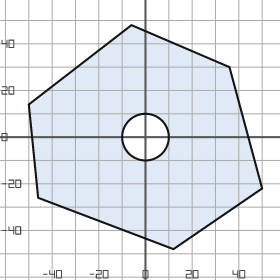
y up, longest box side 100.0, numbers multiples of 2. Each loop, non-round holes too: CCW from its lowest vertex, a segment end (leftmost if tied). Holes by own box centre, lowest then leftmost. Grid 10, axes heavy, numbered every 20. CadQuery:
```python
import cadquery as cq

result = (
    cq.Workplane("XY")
    .moveTo(12.0, -48.0)
    .lineTo(50.0, -22.0)
    .lineTo(36.0, 30.0)
    .lineTo(-6.0, 48.0)
    .lineTo(-50.0, 14.0)
    .lineTo(-46.0, -26.0)
    .close()
    .moveTo(0.0, 0.0)
    .circle(10.0)
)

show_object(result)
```